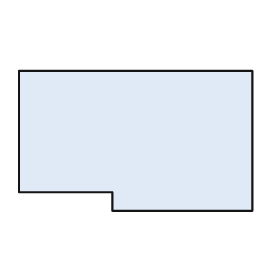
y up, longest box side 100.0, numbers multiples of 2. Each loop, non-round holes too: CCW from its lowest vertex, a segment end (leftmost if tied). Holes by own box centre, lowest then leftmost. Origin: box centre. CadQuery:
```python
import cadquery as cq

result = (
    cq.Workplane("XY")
    .moveTo(-10.0, -30.0)
    .lineTo(50.0, -30.0)
    .lineTo(50.0, 30.0)
    .lineTo(-50.0, 30.0)
    .lineTo(-50.0, -22.0)
    .lineTo(-10.0, -22.0)
    .close()
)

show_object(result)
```